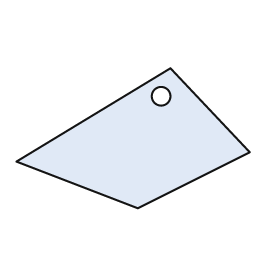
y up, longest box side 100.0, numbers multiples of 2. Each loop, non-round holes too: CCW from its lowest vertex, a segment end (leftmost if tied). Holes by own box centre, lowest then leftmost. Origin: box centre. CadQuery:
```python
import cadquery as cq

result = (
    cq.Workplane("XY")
    .moveTo(2.0, -30.0)
    .lineTo(50.0, -6.0)
    .lineTo(16.0, 30.0)
    .lineTo(-50.0, -10.0)
    .close()
    .moveTo(12.0, 18.0)
    .circle(4.0)
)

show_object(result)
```